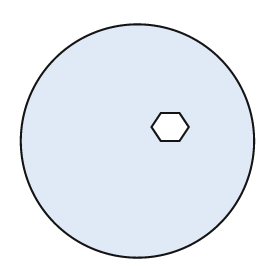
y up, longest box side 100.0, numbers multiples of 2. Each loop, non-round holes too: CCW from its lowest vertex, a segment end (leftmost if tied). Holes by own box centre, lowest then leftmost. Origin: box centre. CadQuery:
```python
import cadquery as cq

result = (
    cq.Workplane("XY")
    .moveTo(0.0, 0.0)
    .circle(50.0)
    .moveTo(10.0, 0.0)
    .lineTo(18.0, 0.0)
    .lineTo(22.0, 6.0)
    .lineTo(18.0, 12.0)
    .lineTo(10.0, 12.0)
    .lineTo(6.0, 6.0)
    .close()
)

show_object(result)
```